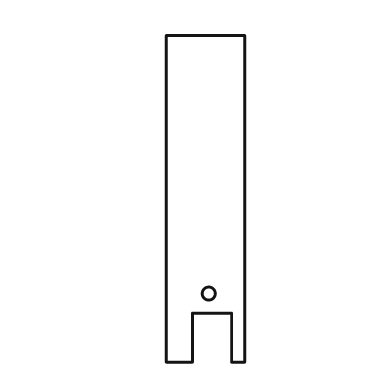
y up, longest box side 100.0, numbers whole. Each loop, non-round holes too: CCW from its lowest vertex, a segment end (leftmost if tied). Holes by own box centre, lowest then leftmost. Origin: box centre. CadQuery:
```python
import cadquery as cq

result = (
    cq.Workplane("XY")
    .moveTo(-12.0, -50.0)
    .lineTo(-4.0, -50.0)
    .lineTo(-4.0, -35.0)
    .lineTo(8.0, -35.0)
    .lineTo(8.0, -50.0)
    .lineTo(12.0, -50.0)
    .lineTo(12.0, 50.0)
    .lineTo(-12.0, 50.0)
    .close()
    .moveTo(1.0, -29.0)
    .circle(2.0)
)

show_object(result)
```